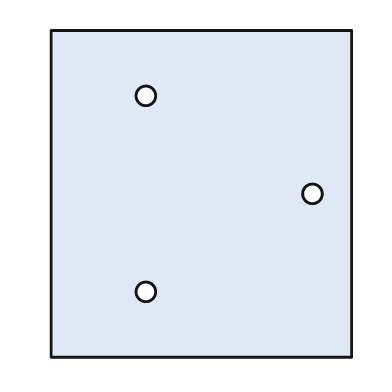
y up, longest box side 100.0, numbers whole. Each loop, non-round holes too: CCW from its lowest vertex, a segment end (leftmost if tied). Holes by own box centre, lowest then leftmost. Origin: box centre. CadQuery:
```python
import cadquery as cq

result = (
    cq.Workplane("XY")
    .moveTo(-46.0, -50.0)
    .lineTo(46.0, -50.0)
    .lineTo(46.0, 50.0)
    .lineTo(-46.0, 50.0)
    .close()
    .moveTo(-17.0, -30.0)
    .circle(3.0)
    .moveTo(34.0, 0.0)
    .circle(3.0)
    .moveTo(-17.0, 30.0)
    .circle(3.0)
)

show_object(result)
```